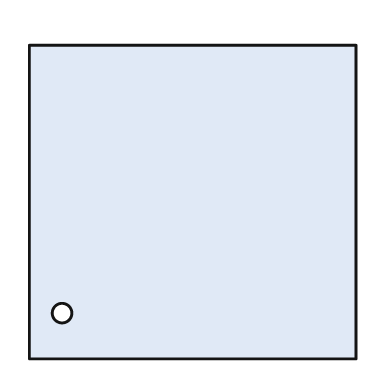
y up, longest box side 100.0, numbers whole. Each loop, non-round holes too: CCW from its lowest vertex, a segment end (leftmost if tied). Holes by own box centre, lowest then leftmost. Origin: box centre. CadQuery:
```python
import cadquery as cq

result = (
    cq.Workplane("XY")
    .moveTo(-50.0, -48.0)
    .lineTo(50.0, -48.0)
    .lineTo(50.0, 48.0)
    .lineTo(-50.0, 48.0)
    .close()
    .moveTo(-40.0, -34.0)
    .circle(3.0)
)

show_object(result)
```